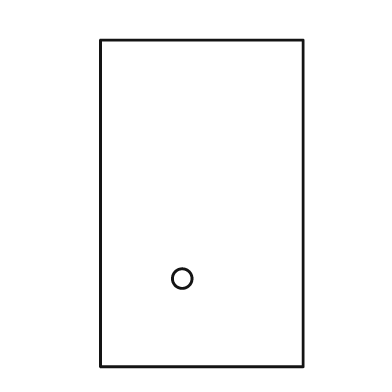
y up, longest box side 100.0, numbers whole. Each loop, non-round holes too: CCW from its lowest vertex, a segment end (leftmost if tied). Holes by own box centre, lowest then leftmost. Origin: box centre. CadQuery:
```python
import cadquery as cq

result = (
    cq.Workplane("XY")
    .moveTo(-31.0, -50.0)
    .lineTo(31.0, -50.0)
    .lineTo(31.0, 50.0)
    .lineTo(-31.0, 50.0)
    .close()
    .moveTo(-6.0, -23.0)
    .circle(3.0)
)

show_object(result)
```